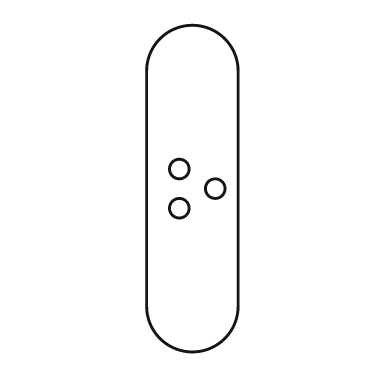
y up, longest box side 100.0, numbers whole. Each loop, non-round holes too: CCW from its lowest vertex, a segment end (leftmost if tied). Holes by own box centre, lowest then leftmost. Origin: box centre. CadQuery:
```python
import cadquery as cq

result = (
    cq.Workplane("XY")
    .moveTo(-14.0, -36.0)
    .threePointArc((0.0, -50.0), (14.0, -36.0))
    .lineTo(14.0, 36.0)
    .threePointArc((0.0, 50.0), (-14.0, 36.0))
    .close()
    .moveTo(-4.0, -6.0)
    .circle(3.0)
    .moveTo(7.0, 0.0)
    .circle(3.0)
    .moveTo(-4.0, 6.0)
    .circle(3.0)
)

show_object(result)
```